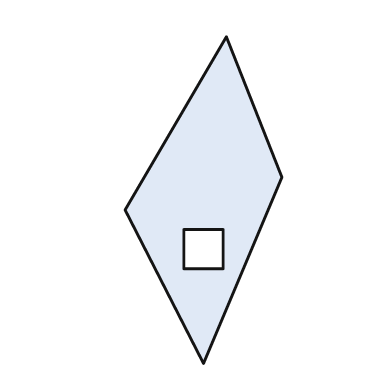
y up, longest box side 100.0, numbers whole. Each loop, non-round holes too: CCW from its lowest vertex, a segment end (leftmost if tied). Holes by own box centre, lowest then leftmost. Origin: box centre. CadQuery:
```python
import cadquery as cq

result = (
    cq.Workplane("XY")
    .moveTo(0.0, -50.0)
    .lineTo(24.0, 7.0)
    .lineTo(7.0, 50.0)
    .lineTo(-24.0, -3.0)
    .close()
    .moveTo(-6.0, -21.0)
    .lineTo(6.0, -21.0)
    .lineTo(6.0, -9.0)
    .lineTo(-6.0, -9.0)
    .close()
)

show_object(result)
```